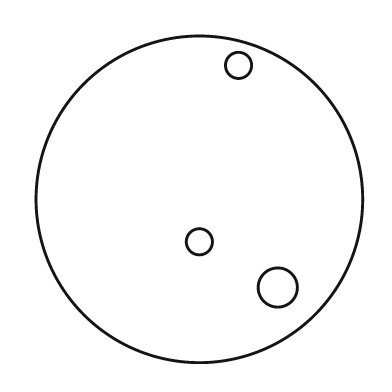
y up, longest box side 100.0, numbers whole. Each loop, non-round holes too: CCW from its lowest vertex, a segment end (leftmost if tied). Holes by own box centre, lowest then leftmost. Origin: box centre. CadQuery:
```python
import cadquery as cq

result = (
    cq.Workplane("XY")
    .moveTo(0.0, 0.0)
    .circle(50.0)
    .moveTo(24.0, -27.0)
    .circle(6.0)
    .moveTo(0.0, -13.0)
    .circle(4.0)
    .moveTo(12.0, 41.0)
    .circle(4.0)
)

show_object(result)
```